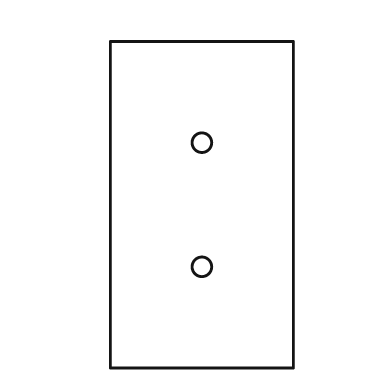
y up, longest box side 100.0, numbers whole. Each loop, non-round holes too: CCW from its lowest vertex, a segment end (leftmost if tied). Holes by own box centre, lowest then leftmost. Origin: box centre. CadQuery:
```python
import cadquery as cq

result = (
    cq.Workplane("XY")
    .moveTo(-28.0, -50.0)
    .lineTo(28.0, -50.0)
    .lineTo(28.0, 50.0)
    .lineTo(-28.0, 50.0)
    .close()
    .moveTo(0.0, -19.0)
    .circle(3.0)
    .moveTo(0.0, 19.0)
    .circle(3.0)
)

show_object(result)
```